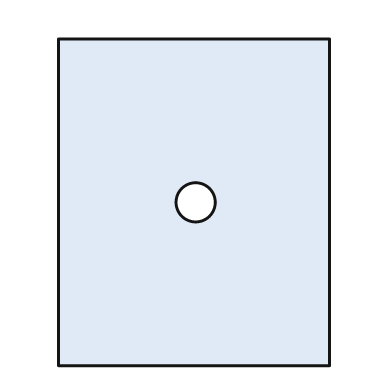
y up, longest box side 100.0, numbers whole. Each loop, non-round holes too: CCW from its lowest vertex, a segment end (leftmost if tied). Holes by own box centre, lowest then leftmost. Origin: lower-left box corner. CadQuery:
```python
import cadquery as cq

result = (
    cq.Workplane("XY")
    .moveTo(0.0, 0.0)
    .lineTo(83.0, 0.0)
    .lineTo(83.0, 100.0)
    .lineTo(0.0, 100.0)
    .close()
    .moveTo(42.0, 50.0)
    .circle(6.0)
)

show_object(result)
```